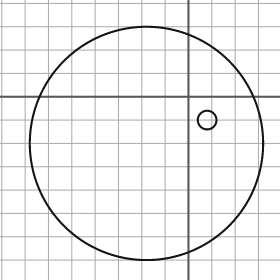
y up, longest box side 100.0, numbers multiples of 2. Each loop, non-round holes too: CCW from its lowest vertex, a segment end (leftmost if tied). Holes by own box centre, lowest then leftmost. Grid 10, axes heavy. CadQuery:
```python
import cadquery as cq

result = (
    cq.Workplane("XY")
    .moveTo(-18.0, -20.0)
    .circle(50.0)
    .moveTo(8.0, -10.0)
    .circle(4.0)
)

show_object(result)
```